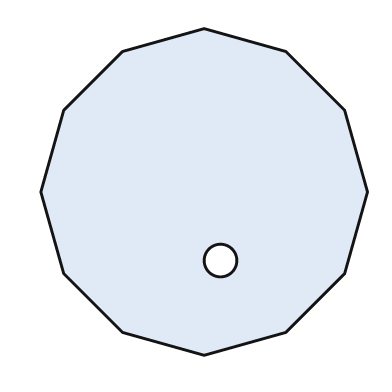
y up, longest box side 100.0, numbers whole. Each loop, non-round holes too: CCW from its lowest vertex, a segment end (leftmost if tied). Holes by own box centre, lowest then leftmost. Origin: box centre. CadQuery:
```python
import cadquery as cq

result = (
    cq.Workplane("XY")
    .moveTo(0.0, -50.0)
    .lineTo(25.0, -43.0)
    .lineTo(43.0, -25.0)
    .lineTo(50.0, 0.0)
    .lineTo(43.0, 25.0)
    .lineTo(25.0, 43.0)
    .lineTo(0.0, 50.0)
    .lineTo(-25.0, 43.0)
    .lineTo(-43.0, 25.0)
    .lineTo(-50.0, 0.0)
    .lineTo(-43.0, -25.0)
    .lineTo(-25.0, -43.0)
    .close()
    .moveTo(5.0, -21.0)
    .circle(5.0)
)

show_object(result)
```